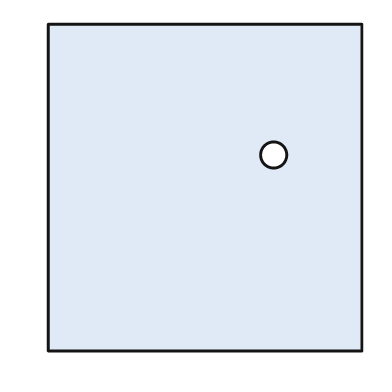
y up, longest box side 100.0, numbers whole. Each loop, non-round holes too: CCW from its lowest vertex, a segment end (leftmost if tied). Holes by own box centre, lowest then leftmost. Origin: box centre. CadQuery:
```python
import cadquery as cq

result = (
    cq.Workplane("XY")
    .moveTo(-48.0, -50.0)
    .lineTo(48.0, -50.0)
    .lineTo(48.0, 50.0)
    .lineTo(-48.0, 50.0)
    .close()
    .moveTo(21.0, 10.0)
    .circle(4.0)
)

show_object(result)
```